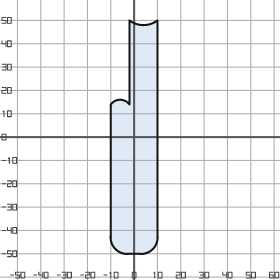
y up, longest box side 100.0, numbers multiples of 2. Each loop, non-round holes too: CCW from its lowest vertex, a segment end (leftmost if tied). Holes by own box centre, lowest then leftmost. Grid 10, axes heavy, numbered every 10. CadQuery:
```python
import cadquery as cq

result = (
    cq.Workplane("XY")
    .moveTo(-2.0, -50.0)
    .lineTo(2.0, -50.0)
    .threePointArc((8.0, -48.0), (10.0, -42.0))
    .lineTo(10.0, 50.0)
    .threePointArc((4.0, 48.0), (-2.0, 50.0))
    .lineTo(-2.0, 14.0)
    .threePointArc((-6.0, 16.0), (-10.0, 14.0))
    .lineTo(-10.0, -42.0)
    .threePointArc((-8.0, -48.0), (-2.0, -50.0))
    .close()
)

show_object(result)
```